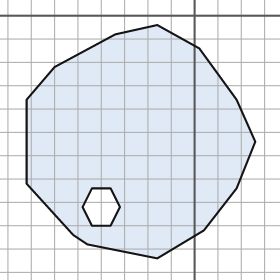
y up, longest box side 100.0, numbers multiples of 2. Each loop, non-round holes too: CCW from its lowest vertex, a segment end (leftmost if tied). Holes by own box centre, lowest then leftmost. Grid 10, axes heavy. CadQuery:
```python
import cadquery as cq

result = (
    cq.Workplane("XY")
    .moveTo(-16.0, -104.0)
    .lineTo(4.0, -92.0)
    .lineTo(18.0, -74.0)
    .lineTo(26.0, -54.0)
    .lineTo(18.0, -36.0)
    .lineTo(2.0, -14.0)
    .lineTo(-16.0, -4.0)
    .lineTo(-34.0, -8.0)
    .lineTo(-60.0, -22.0)
    .lineTo(-72.0, -36.0)
    .lineTo(-72.0, -72.0)
    .lineTo(-52.0, -94.0)
    .lineTo(-46.0, -98.0)
    .close()
    .moveTo(-44.0, -90.0)
    .lineTo(-36.0, -90.0)
    .lineTo(-32.0, -82.0)
    .lineTo(-36.0, -74.0)
    .lineTo(-44.0, -74.0)
    .lineTo(-48.0, -82.0)
    .close()
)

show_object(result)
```